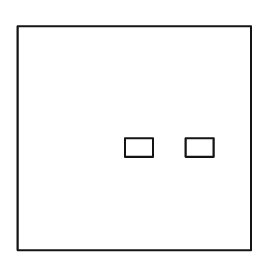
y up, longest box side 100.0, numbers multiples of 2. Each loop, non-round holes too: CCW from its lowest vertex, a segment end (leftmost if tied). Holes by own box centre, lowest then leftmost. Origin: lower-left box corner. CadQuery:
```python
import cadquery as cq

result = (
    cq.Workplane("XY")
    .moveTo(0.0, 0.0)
    .lineTo(100.0, 0.0)
    .lineTo(100.0, 96.0)
    .lineTo(0.0, 96.0)
    .close()
    .moveTo(46.0, 40.0)
    .lineTo(58.0, 40.0)
    .lineTo(58.0, 48.0)
    .lineTo(46.0, 48.0)
    .close()
    .moveTo(72.0, 40.0)
    .lineTo(84.0, 40.0)
    .lineTo(84.0, 48.0)
    .lineTo(72.0, 48.0)
    .close()
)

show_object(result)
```